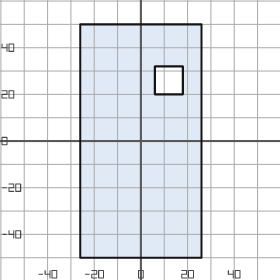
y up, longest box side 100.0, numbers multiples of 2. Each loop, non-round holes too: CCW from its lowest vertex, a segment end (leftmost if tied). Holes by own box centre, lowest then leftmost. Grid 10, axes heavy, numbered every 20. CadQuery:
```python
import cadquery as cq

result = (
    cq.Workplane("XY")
    .moveTo(-26.0, -50.0)
    .lineTo(26.0, -50.0)
    .lineTo(26.0, 50.0)
    .lineTo(-26.0, 50.0)
    .close()
    .moveTo(6.0, 20.0)
    .lineTo(18.0, 20.0)
    .lineTo(18.0, 32.0)
    .lineTo(6.0, 32.0)
    .close()
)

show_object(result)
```